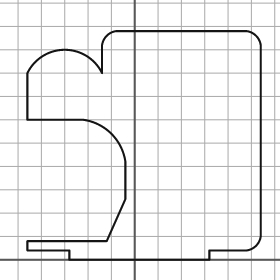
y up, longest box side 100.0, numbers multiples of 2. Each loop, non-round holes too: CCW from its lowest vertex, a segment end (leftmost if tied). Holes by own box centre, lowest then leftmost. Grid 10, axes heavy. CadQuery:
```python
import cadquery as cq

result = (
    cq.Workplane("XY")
    .moveTo(-28.0, 0.0)
    .lineTo(32.0, 0.0)
    .lineTo(32.0, 4.0)
    .lineTo(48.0, 4.0)
    .threePointArc((52.0, 6.0), (54.0, 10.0))
    .lineTo(54.0, 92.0)
    .threePointArc((52.0, 96.0), (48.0, 98.0))
    .lineTo(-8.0, 98.0)
    .threePointArc((-12.0, 96.0), (-14.0, 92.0))
    .lineTo(-14.0, 80.0)
    .threePointArc((-30.0, 90.0), (-46.0, 80.0))
    .lineTo(-46.0, 60.0)
    .lineTo(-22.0, 60.0)
    .threePointArc((-10.0, 54.0), (-4.0, 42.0))
    .lineTo(-4.0, 26.0)
    .lineTo(-12.0, 8.0)
    .lineTo(-46.0, 8.0)
    .lineTo(-46.0, 4.0)
    .lineTo(-28.0, 4.0)
    .close()
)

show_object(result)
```